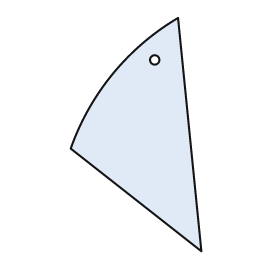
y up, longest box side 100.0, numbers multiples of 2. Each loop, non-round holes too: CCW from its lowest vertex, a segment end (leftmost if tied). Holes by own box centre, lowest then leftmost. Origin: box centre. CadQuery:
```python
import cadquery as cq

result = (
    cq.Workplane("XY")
    .moveTo(28.0, -50.0)
    .lineTo(18.0, 50.0)
    .threePointArc((-10.0, 26.0), (-28.0, -6.0))
    .close()
    .moveTo(8.0, 32.0)
    .circle(2.0)
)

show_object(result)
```